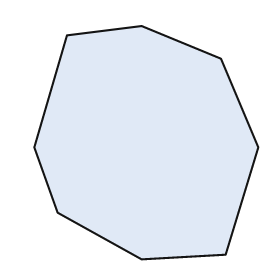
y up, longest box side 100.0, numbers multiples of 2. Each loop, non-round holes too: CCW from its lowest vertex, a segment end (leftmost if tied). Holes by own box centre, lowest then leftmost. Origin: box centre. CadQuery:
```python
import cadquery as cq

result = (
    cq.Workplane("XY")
    .moveTo(-2.0, -50.0)
    .lineTo(34.0, -48.0)
    .lineTo(48.0, -2.0)
    .lineTo(32.0, 36.0)
    .lineTo(-2.0, 50.0)
    .lineTo(-34.0, 46.0)
    .lineTo(-48.0, -2.0)
    .lineTo(-38.0, -30.0)
    .close()
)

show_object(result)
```